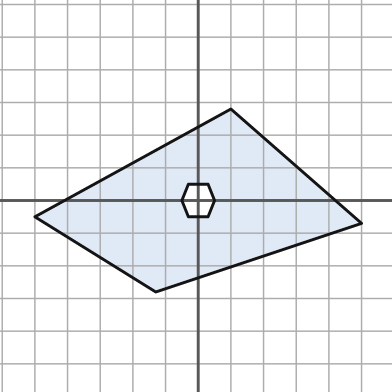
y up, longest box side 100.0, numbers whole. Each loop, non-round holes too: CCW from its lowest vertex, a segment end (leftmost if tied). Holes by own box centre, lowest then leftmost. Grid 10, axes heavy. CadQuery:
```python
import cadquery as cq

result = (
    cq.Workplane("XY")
    .moveTo(-13.0, -28.0)
    .lineTo(50.0, -7.0)
    .lineTo(10.0, 28.0)
    .lineTo(-50.0, -5.0)
    .close()
    .moveTo(-3.0, -5.0)
    .lineTo(3.0, -5.0)
    .lineTo(5.0, 0.0)
    .lineTo(3.0, 5.0)
    .lineTo(-3.0, 5.0)
    .lineTo(-5.0, 0.0)
    .close()
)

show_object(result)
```